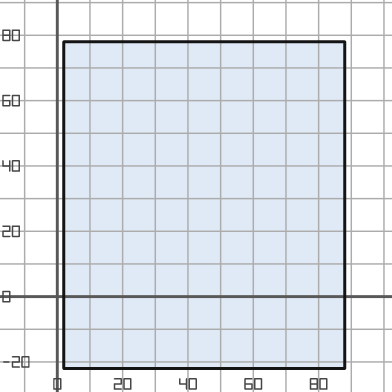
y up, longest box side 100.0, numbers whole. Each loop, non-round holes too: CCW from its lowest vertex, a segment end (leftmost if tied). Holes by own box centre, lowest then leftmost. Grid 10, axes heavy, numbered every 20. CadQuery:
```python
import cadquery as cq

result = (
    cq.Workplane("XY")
    .moveTo(2.0, -22.0)
    .lineTo(88.0, -22.0)
    .lineTo(88.0, 78.0)
    .lineTo(2.0, 78.0)
    .close()
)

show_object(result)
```